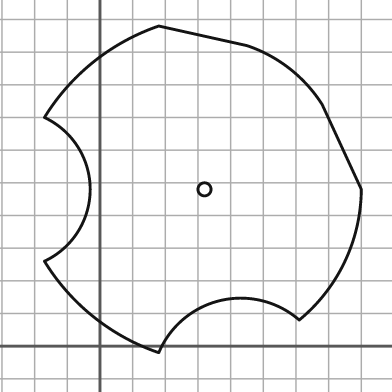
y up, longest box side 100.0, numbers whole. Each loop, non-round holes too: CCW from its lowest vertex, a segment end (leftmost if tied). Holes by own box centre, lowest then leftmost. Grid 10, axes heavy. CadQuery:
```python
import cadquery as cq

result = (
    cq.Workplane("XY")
    .moveTo(18.0, -2.0)
    .threePointArc((37.0, 14.0), (61.0, 8.0))
    .threePointArc((75.0, 26.0), (80.0, 48.0))
    .lineTo(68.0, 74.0)
    .threePointArc((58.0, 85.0), (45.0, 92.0))
    .lineTo(18.0, 98.0)
    .threePointArc((-2.0, 87.0), (-17.0, 70.0))
    .threePointArc((-3.0, 48.0), (-17.0, 26.0))
    .threePointArc((-2.0, 9.0), (18.0, -2.0))
    .close()
    .moveTo(32.0, 48.0)
    .circle(2.0)
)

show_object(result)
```